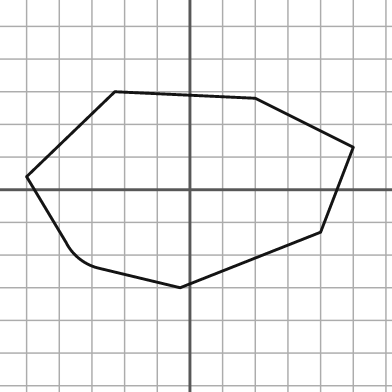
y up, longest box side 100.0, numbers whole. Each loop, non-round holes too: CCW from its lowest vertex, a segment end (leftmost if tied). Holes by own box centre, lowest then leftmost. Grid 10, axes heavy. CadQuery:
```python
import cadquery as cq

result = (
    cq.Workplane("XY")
    .moveTo(-3.0, -30.0)
    .lineTo(40.0, -13.0)
    .lineTo(50.0, 13.0)
    .lineTo(20.0, 28.0)
    .lineTo(-23.0, 30.0)
    .lineTo(-50.0, 4.0)
    .lineTo(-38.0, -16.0)
    .threePointArc((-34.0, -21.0), (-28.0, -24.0))
    .close()
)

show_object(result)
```